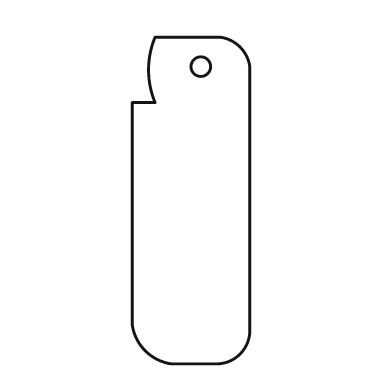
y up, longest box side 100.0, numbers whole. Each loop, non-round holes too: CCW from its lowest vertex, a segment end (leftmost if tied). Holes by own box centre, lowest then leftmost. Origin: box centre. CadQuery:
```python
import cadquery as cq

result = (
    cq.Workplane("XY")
    .moveTo(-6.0, -50.0)
    .lineTo(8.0, -50.0)
    .threePointArc((15.0, -47.0), (18.0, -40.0))
    .lineTo(18.0, 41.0)
    .threePointArc((15.0, 47.0), (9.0, 50.0))
    .lineTo(-11.0, 50.0)
    .threePointArc((-13.0, 40.0), (-11.0, 30.0))
    .lineTo(-18.0, 30.0)
    .lineTo(-18.0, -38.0)
    .threePointArc((-14.0, -46.0), (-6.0, -50.0))
    .close()
    .moveTo(3.0, 41.0)
    .circle(3.0)
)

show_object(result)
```